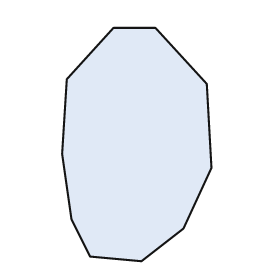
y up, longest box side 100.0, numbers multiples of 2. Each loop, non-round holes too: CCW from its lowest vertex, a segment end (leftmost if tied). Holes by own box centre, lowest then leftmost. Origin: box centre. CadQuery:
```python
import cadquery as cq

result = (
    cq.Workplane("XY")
    .moveTo(2.0, -50.0)
    .lineTo(20.0, -36.0)
    .lineTo(32.0, -10.0)
    .lineTo(30.0, 26.0)
    .lineTo(8.0, 50.0)
    .lineTo(-10.0, 50.0)
    .lineTo(-30.0, 28.0)
    .lineTo(-32.0, -4.0)
    .lineTo(-28.0, -32.0)
    .lineTo(-20.0, -48.0)
    .close()
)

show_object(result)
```